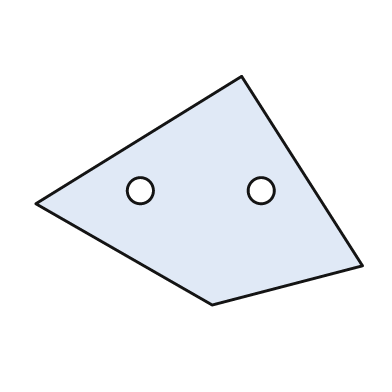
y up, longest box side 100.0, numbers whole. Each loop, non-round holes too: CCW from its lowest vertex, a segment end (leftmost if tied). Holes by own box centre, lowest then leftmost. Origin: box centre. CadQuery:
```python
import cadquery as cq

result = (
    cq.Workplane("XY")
    .moveTo(4.0, -35.0)
    .lineTo(50.0, -23.0)
    .lineTo(13.0, 35.0)
    .lineTo(-50.0, -4.0)
    .close()
    .moveTo(-18.0, 0.0)
    .circle(4.0)
    .moveTo(19.0, 0.0)
    .circle(4.0)
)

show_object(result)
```